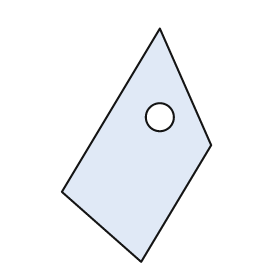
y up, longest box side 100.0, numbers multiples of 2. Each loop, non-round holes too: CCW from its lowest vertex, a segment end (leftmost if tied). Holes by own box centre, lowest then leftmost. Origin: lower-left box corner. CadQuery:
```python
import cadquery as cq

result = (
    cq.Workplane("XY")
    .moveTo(34.0, 0.0)
    .lineTo(64.0, 50.0)
    .lineTo(42.0, 100.0)
    .lineTo(0.0, 30.0)
    .close()
    .moveTo(42.0, 62.0)
    .circle(6.0)
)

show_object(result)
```